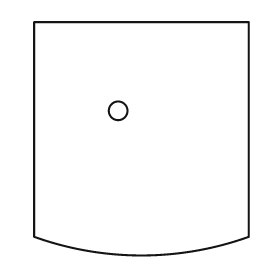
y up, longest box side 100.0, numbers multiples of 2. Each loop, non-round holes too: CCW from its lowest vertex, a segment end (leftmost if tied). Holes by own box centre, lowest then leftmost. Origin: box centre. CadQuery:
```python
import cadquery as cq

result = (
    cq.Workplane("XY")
    .moveTo(-46.0, -42.0)
    .threePointArc((0.0, -50.0), (46.0, -42.0))
    .lineTo(46.0, 50.0)
    .lineTo(-46.0, 50.0)
    .close()
    .moveTo(-10.0, 12.0)
    .circle(4.0)
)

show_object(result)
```